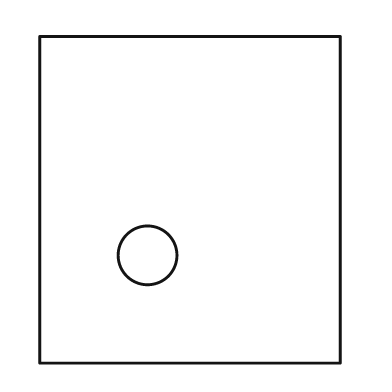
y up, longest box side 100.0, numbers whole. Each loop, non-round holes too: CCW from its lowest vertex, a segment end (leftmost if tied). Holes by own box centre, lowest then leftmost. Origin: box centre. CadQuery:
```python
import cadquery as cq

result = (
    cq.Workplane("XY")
    .moveTo(-46.0, -50.0)
    .lineTo(46.0, -50.0)
    .lineTo(46.0, 50.0)
    .lineTo(-46.0, 50.0)
    .close()
    .moveTo(-13.0, -17.0)
    .circle(9.0)
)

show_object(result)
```